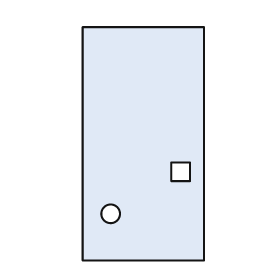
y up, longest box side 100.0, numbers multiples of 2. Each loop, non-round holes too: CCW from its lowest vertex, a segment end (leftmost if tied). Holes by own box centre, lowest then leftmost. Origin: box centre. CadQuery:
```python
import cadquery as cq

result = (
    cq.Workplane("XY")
    .moveTo(-26.0, -50.0)
    .lineTo(26.0, -50.0)
    .lineTo(26.0, 50.0)
    .lineTo(-26.0, 50.0)
    .close()
    .moveTo(-14.0, -30.0)
    .circle(4.0)
    .moveTo(12.0, -16.0)
    .lineTo(20.0, -16.0)
    .lineTo(20.0, -8.0)
    .lineTo(12.0, -8.0)
    .close()
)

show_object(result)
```